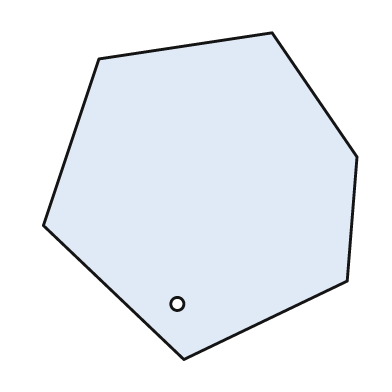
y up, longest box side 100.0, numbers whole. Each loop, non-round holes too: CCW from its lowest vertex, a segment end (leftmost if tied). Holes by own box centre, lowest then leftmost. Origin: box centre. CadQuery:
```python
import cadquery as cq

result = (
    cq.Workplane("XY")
    .moveTo(-5.0, -50.0)
    .lineTo(45.0, -26.0)
    .lineTo(48.0, 12.0)
    .lineTo(22.0, 50.0)
    .lineTo(-31.0, 42.0)
    .lineTo(-48.0, -9.0)
    .close()
    .moveTo(-7.0, -33.0)
    .circle(2.0)
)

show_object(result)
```